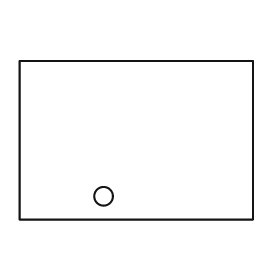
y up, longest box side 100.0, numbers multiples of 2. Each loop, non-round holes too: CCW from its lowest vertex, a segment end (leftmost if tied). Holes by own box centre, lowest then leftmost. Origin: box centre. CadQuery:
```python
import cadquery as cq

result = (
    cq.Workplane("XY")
    .moveTo(-50.0, -34.0)
    .lineTo(50.0, -34.0)
    .lineTo(50.0, 34.0)
    .lineTo(-50.0, 34.0)
    .close()
    .moveTo(-14.0, -24.0)
    .circle(4.0)
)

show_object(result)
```